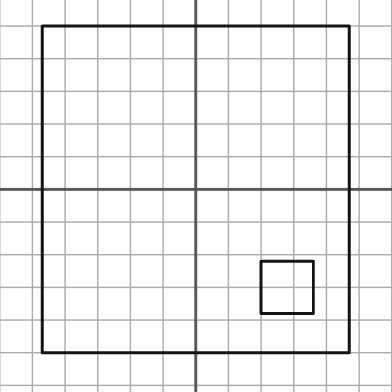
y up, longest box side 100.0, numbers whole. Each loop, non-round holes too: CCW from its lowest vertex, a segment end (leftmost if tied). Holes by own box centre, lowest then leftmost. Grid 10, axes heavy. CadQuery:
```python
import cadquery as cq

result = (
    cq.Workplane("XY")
    .moveTo(-47.0, -50.0)
    .lineTo(47.0, -50.0)
    .lineTo(47.0, 50.0)
    .lineTo(-47.0, 50.0)
    .close()
    .moveTo(20.0, -38.0)
    .lineTo(36.0, -38.0)
    .lineTo(36.0, -22.0)
    .lineTo(20.0, -22.0)
    .close()
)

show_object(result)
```